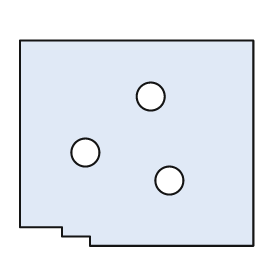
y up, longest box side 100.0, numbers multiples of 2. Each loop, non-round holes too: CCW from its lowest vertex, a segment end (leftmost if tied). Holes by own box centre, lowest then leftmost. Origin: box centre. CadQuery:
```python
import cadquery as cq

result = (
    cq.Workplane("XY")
    .moveTo(-20.0, -44.0)
    .lineTo(50.0, -44.0)
    .lineTo(50.0, 44.0)
    .lineTo(-50.0, 44.0)
    .lineTo(-50.0, -36.0)
    .lineTo(-32.0, -36.0)
    .lineTo(-32.0, -40.0)
    .lineTo(-20.0, -40.0)
    .close()
    .moveTo(14.0, -16.0)
    .circle(6.0)
    .moveTo(-22.0, -4.0)
    .circle(6.0)
    .moveTo(6.0, 20.0)
    .circle(6.0)
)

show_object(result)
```